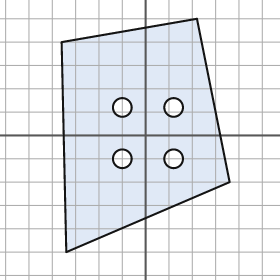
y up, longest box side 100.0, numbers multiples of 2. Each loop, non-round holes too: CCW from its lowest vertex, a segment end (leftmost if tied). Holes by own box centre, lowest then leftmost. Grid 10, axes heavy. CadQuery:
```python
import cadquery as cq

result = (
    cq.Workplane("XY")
    .moveTo(-34.0, -50.0)
    .lineTo(36.0, -20.0)
    .lineTo(22.0, 50.0)
    .lineTo(-36.0, 40.0)
    .close()
    .moveTo(-10.0, -10.0)
    .circle(4.0)
    .moveTo(12.0, -10.0)
    .circle(4.0)
    .moveTo(-10.0, 12.0)
    .circle(4.0)
    .moveTo(12.0, 12.0)
    .circle(4.0)
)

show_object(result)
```